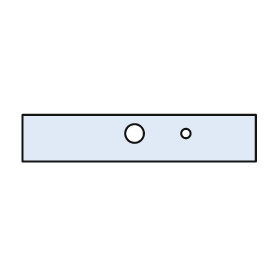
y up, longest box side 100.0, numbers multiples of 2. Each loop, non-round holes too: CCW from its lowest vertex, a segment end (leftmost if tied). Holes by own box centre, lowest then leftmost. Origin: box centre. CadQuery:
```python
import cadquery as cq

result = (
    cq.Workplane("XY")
    .moveTo(-50.0, -10.0)
    .lineTo(50.0, -10.0)
    .lineTo(50.0, 10.0)
    .lineTo(-50.0, 10.0)
    .close()
    .moveTo(-2.0, 2.0)
    .circle(4.0)
    .moveTo(20.0, 2.0)
    .circle(2.0)
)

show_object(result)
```